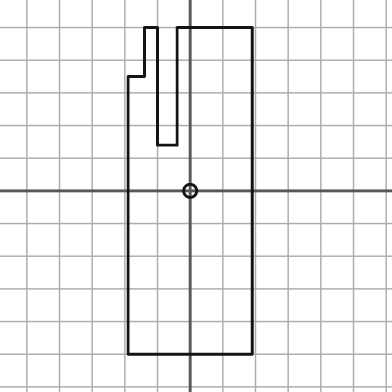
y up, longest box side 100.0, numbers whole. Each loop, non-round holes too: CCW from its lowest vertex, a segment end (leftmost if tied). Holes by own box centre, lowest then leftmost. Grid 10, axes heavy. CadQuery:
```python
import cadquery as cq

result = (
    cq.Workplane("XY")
    .moveTo(-19.0, -50.0)
    .lineTo(19.0, -50.0)
    .lineTo(19.0, 50.0)
    .lineTo(-4.0, 50.0)
    .lineTo(-4.0, 14.0)
    .lineTo(-10.0, 14.0)
    .lineTo(-10.0, 50.0)
    .lineTo(-14.0, 50.0)
    .lineTo(-14.0, 35.0)
    .lineTo(-19.0, 35.0)
    .close()
    .moveTo(0.0, 0.0)
    .circle(2.0)
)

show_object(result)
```